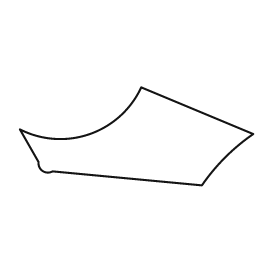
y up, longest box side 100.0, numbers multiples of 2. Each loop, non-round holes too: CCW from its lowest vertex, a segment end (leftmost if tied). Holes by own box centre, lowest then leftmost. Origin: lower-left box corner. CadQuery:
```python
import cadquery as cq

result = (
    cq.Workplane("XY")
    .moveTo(78.0, 0.0)
    .threePointArc((88.0, 12.0), (100.0, 22.0))
    .lineTo(52.0, 42.0)
    .threePointArc((30.0, 22.0), (0.0, 24.0))
    .lineTo(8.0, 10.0)
    .threePointArc((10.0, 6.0), (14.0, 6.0))
    .close()
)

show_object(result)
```